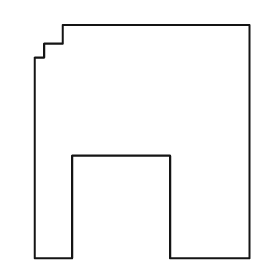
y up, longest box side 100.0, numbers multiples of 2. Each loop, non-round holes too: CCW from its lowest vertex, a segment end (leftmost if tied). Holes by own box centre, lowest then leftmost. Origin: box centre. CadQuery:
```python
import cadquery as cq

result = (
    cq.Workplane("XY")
    .moveTo(-46.0, -50.0)
    .lineTo(-30.0, -50.0)
    .lineTo(-30.0, -6.0)
    .lineTo(12.0, -6.0)
    .lineTo(12.0, -50.0)
    .lineTo(46.0, -50.0)
    .lineTo(46.0, 50.0)
    .lineTo(-34.0, 50.0)
    .lineTo(-34.0, 42.0)
    .lineTo(-42.0, 42.0)
    .lineTo(-42.0, 36.0)
    .lineTo(-46.0, 36.0)
    .close()
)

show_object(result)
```